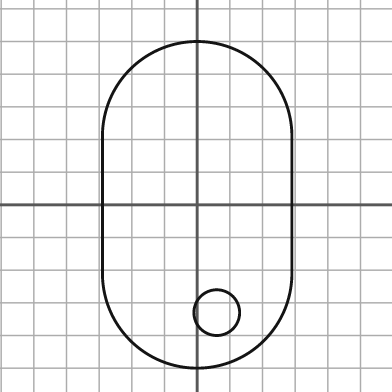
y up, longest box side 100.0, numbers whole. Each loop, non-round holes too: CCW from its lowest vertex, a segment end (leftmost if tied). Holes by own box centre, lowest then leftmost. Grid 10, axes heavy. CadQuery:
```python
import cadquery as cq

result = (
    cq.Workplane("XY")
    .moveTo(-29.0, -21.0)
    .threePointArc((0.0, -50.0), (29.0, -21.0))
    .lineTo(29.0, 21.0)
    .threePointArc((0.0, 50.0), (-29.0, 21.0))
    .close()
    .moveTo(6.0, -33.0)
    .circle(7.0)
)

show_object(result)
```